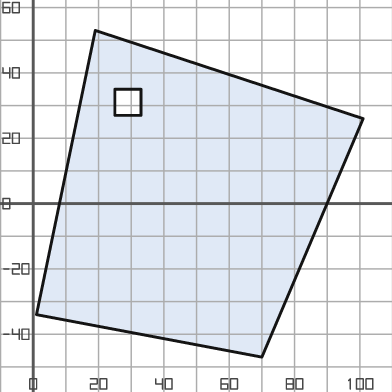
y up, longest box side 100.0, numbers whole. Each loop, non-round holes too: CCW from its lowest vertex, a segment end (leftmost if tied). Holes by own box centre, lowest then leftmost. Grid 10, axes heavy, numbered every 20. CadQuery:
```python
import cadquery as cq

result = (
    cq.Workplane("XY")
    .moveTo(70.0, -47.0)
    .lineTo(101.0, 26.0)
    .lineTo(19.0, 53.0)
    .lineTo(1.0, -34.0)
    .close()
    .moveTo(25.0, 27.0)
    .lineTo(33.0, 27.0)
    .lineTo(33.0, 35.0)
    .lineTo(25.0, 35.0)
    .close()
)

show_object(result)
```